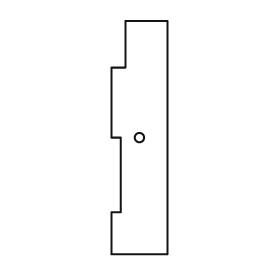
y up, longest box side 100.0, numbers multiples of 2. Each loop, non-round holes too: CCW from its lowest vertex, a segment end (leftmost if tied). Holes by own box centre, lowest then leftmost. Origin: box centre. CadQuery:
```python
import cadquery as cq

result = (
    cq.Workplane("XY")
    .moveTo(-12.0, -50.0)
    .lineTo(12.0, -50.0)
    .lineTo(12.0, 50.0)
    .lineTo(-6.0, 50.0)
    .lineTo(-6.0, 30.0)
    .lineTo(-12.0, 30.0)
    .lineTo(-12.0, 0.0)
    .lineTo(-8.0, 0.0)
    .lineTo(-8.0, -32.0)
    .lineTo(-12.0, -32.0)
    .close()
    .moveTo(0.0, 0.0)
    .circle(2.0)
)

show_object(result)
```